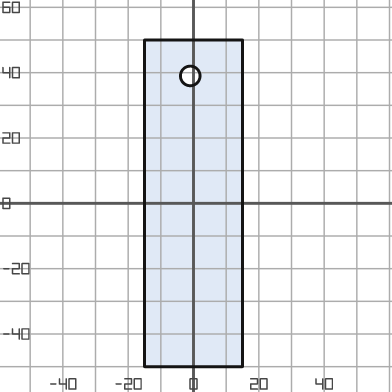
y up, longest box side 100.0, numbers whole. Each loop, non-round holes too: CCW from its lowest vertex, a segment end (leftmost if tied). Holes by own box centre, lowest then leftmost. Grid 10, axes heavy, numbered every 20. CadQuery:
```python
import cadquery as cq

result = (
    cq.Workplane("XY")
    .moveTo(-15.0, -50.0)
    .lineTo(15.0, -50.0)
    .lineTo(15.0, 50.0)
    .lineTo(-15.0, 50.0)
    .close()
    .moveTo(-1.0, 39.0)
    .circle(3.0)
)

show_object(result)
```